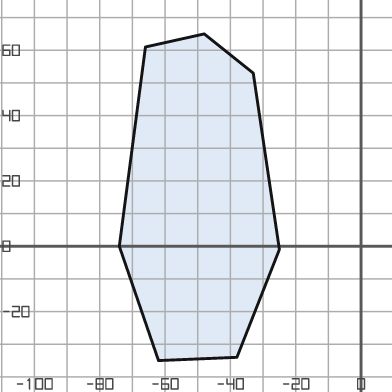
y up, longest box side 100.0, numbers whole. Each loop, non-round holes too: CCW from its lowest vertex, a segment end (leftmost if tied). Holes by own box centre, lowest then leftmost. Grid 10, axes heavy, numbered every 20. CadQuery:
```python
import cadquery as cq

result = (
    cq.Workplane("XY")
    .moveTo(-62.0, -35.0)
    .lineTo(-38.0, -34.0)
    .lineTo(-25.0, -1.0)
    .lineTo(-33.0, 53.0)
    .lineTo(-48.0, 65.0)
    .lineTo(-66.0, 61.0)
    .lineTo(-74.0, 0.0)
    .close()
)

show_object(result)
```